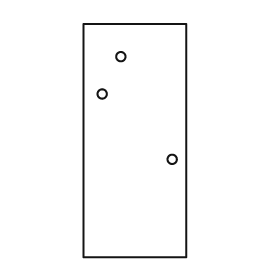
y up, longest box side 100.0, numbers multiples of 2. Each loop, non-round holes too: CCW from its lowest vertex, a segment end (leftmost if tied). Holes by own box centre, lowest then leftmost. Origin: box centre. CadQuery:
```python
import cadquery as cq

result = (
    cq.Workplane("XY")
    .moveTo(-22.0, -50.0)
    .lineTo(22.0, -50.0)
    .lineTo(22.0, 50.0)
    .lineTo(-22.0, 50.0)
    .close()
    .moveTo(16.0, -8.0)
    .circle(2.0)
    .moveTo(-14.0, 20.0)
    .circle(2.0)
    .moveTo(-6.0, 36.0)
    .circle(2.0)
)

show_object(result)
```